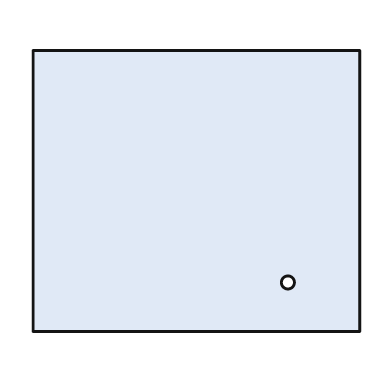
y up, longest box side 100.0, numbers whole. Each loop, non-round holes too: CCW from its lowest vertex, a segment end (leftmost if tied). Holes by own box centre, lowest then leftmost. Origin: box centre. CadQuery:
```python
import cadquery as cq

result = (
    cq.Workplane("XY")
    .moveTo(-50.0, -43.0)
    .lineTo(50.0, -43.0)
    .lineTo(50.0, 43.0)
    .lineTo(-50.0, 43.0)
    .close()
    .moveTo(28.0, -28.0)
    .circle(2.0)
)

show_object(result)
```